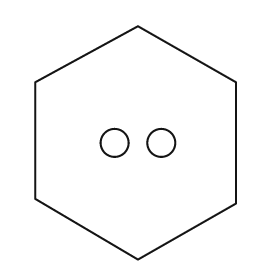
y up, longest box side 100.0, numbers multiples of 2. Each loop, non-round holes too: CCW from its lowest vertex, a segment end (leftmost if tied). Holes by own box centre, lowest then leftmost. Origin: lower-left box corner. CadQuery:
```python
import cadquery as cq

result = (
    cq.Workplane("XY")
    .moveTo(44.0, 0.0)
    .lineTo(86.0, 24.0)
    .lineTo(86.0, 76.0)
    .lineTo(44.0, 100.0)
    .lineTo(0.0, 76.0)
    .lineTo(0.0, 26.0)
    .close()
    .moveTo(34.0, 50.0)
    .circle(6.0)
    .moveTo(54.0, 50.0)
    .circle(6.0)
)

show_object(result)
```